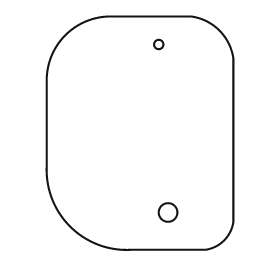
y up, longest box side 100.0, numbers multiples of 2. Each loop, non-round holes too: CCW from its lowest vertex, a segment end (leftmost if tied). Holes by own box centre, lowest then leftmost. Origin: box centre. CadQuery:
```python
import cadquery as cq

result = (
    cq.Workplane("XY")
    .moveTo(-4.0, -50.0)
    .lineTo(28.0, -50.0)
    .threePointArc((36.0, -46.0), (40.0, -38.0))
    .lineTo(40.0, 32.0)
    .threePointArc((34.0, 44.0), (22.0, 50.0))
    .lineTo(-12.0, 50.0)
    .threePointArc((-32.0, 42.0), (-40.0, 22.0))
    .lineTo(-40.0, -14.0)
    .threePointArc((-30.0, -40.0), (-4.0, -50.0))
    .close()
    .moveTo(12.0, -34.0)
    .circle(4.0)
    .moveTo(8.0, 38.0)
    .circle(2.0)
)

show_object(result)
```